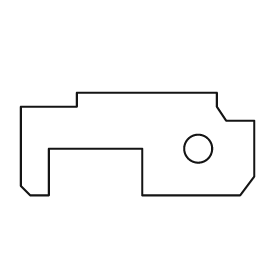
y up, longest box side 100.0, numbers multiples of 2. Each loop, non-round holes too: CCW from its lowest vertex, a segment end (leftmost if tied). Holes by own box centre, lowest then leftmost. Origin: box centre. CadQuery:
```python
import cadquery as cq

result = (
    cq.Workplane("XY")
    .moveTo(-46.0, -22.0)
    .lineTo(-38.0, -22.0)
    .lineTo(-38.0, -2.0)
    .lineTo(2.0, -2.0)
    .lineTo(2.0, -22.0)
    .lineTo(44.0, -22.0)
    .lineTo(50.0, -14.0)
    .lineTo(50.0, 10.0)
    .lineTo(38.0, 10.0)
    .lineTo(34.0, 16.0)
    .lineTo(34.0, 22.0)
    .lineTo(-26.0, 22.0)
    .lineTo(-26.0, 16.0)
    .lineTo(-50.0, 16.0)
    .lineTo(-50.0, -18.0)
    .close()
    .moveTo(26.0, -2.0)
    .circle(6.0)
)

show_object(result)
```